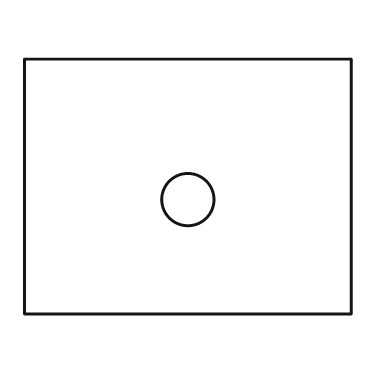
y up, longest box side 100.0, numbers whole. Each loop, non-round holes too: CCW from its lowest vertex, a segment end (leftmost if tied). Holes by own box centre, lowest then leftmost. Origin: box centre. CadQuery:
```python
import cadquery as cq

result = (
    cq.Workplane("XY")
    .moveTo(-50.0, -39.0)
    .lineTo(50.0, -39.0)
    .lineTo(50.0, 39.0)
    .lineTo(-50.0, 39.0)
    .close()
    .moveTo(0.0, -4.0)
    .circle(8.0)
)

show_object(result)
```